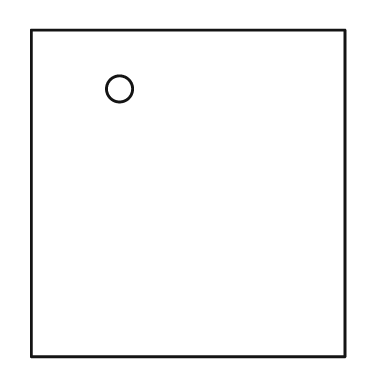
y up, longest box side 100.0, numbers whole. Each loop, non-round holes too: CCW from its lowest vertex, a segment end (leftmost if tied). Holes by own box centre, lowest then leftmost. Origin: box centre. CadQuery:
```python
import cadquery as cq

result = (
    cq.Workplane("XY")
    .moveTo(-48.0, -50.0)
    .lineTo(48.0, -50.0)
    .lineTo(48.0, 50.0)
    .lineTo(-48.0, 50.0)
    .close()
    .moveTo(-21.0, 32.0)
    .circle(4.0)
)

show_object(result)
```